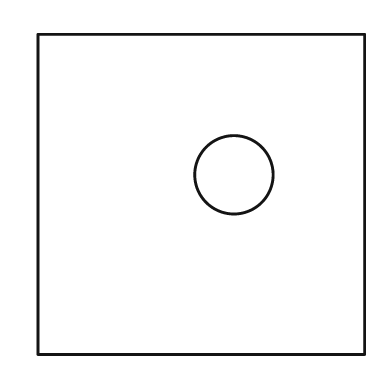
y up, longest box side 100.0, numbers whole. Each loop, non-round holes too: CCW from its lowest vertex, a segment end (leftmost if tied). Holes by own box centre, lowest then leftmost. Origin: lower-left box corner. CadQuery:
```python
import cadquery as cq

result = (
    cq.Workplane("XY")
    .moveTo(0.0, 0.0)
    .lineTo(100.0, 0.0)
    .lineTo(100.0, 98.0)
    .lineTo(0.0, 98.0)
    .close()
    .moveTo(60.0, 55.0)
    .circle(12.0)
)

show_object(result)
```